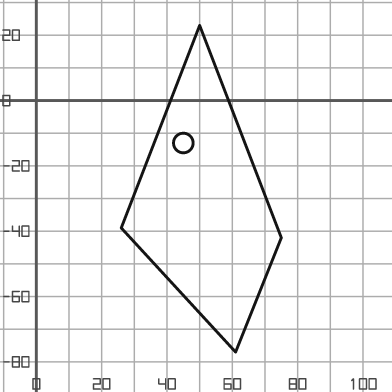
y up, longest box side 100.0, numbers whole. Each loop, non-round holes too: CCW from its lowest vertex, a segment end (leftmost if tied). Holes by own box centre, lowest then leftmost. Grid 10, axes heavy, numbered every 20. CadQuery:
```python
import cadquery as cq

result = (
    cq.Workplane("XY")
    .moveTo(61.0, -77.0)
    .lineTo(75.0, -42.0)
    .lineTo(50.0, 23.0)
    .lineTo(26.0, -39.0)
    .close()
    .moveTo(45.0, -13.0)
    .circle(3.0)
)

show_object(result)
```